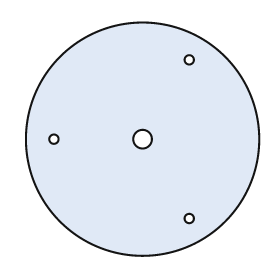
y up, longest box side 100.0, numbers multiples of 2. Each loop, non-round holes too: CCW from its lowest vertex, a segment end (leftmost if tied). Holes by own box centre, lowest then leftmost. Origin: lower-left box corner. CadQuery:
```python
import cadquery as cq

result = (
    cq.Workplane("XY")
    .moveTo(50.0, 50.0)
    .circle(50.0)
    .moveTo(70.0, 16.0)
    .circle(2.0)
    .moveTo(12.0, 50.0)
    .circle(2.0)
    .moveTo(50.0, 50.0)
    .circle(4.0)
    .moveTo(70.0, 84.0)
    .circle(2.0)
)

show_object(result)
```